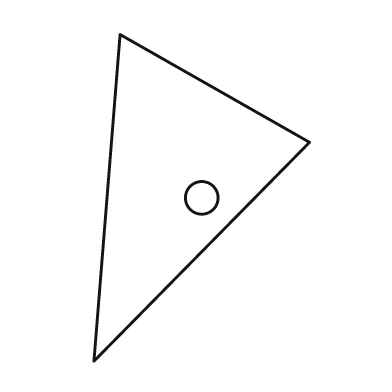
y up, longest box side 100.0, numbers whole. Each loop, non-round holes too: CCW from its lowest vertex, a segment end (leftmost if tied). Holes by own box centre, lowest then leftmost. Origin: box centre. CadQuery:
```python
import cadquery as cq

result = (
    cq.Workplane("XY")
    .moveTo(-33.0, -50.0)
    .lineTo(33.0, 17.0)
    .lineTo(-25.0, 50.0)
    .close()
    .moveTo(0.0, 0.0)
    .circle(5.0)
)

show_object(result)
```